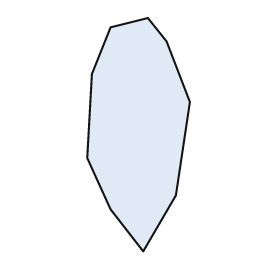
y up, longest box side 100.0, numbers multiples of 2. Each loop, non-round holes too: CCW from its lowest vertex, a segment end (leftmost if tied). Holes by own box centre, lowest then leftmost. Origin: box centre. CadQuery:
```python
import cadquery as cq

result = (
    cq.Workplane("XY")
    .moveTo(2.0, -50.0)
    .lineTo(16.0, -26.0)
    .lineTo(22.0, 14.0)
    .lineTo(12.0, 40.0)
    .lineTo(4.0, 50.0)
    .lineTo(-12.0, 46.0)
    .lineTo(-20.0, 26.0)
    .lineTo(-22.0, -10.0)
    .lineTo(-12.0, -32.0)
    .close()
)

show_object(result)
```